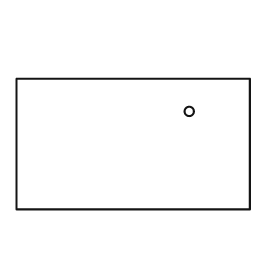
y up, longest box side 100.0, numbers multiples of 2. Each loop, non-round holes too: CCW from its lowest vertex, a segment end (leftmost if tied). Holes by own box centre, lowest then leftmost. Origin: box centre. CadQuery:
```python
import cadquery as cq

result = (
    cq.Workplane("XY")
    .moveTo(-50.0, -28.0)
    .lineTo(50.0, -28.0)
    .lineTo(50.0, 28.0)
    .lineTo(-50.0, 28.0)
    .close()
    .moveTo(24.0, 14.0)
    .circle(2.0)
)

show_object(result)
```